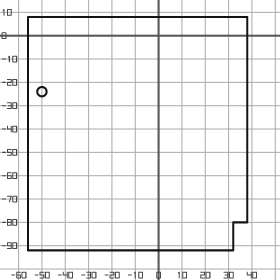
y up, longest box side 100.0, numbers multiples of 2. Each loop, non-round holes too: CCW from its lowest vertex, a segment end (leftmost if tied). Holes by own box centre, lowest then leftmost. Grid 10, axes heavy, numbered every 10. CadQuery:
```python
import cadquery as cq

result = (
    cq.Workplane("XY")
    .moveTo(-56.0, -92.0)
    .lineTo(32.0, -92.0)
    .lineTo(32.0, -80.0)
    .lineTo(38.0, -80.0)
    .lineTo(38.0, 8.0)
    .lineTo(-56.0, 8.0)
    .close()
    .moveTo(-50.0, -24.0)
    .circle(2.0)
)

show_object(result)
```